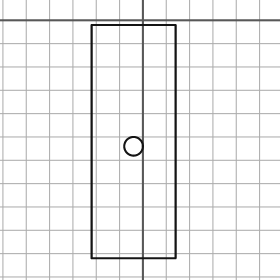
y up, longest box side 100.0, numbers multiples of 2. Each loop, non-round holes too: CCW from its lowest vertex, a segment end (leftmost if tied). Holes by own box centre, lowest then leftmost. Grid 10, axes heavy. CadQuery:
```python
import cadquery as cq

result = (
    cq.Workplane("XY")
    .moveTo(-22.0, -102.0)
    .lineTo(14.0, -102.0)
    .lineTo(14.0, -2.0)
    .lineTo(-22.0, -2.0)
    .close()
    .moveTo(-4.0, -54.0)
    .circle(4.0)
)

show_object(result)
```